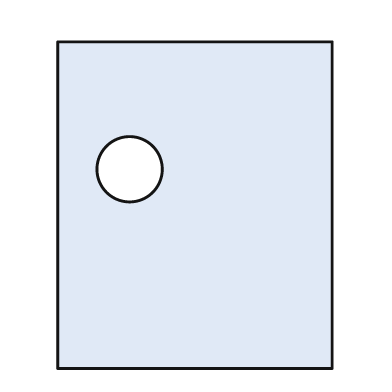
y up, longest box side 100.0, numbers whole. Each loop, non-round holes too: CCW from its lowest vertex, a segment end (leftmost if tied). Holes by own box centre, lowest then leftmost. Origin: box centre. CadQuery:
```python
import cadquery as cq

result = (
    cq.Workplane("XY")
    .moveTo(-42.0, -50.0)
    .lineTo(42.0, -50.0)
    .lineTo(42.0, 50.0)
    .lineTo(-42.0, 50.0)
    .close()
    .moveTo(-20.0, 11.0)
    .circle(10.0)
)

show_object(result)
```